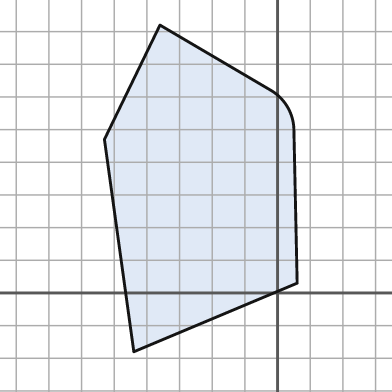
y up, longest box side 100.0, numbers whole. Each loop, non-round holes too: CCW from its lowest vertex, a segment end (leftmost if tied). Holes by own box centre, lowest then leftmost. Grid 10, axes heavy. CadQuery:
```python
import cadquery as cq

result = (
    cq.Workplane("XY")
    .moveTo(-44.0, -18.0)
    .lineTo(6.0, 3.0)
    .lineTo(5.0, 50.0)
    .threePointArc((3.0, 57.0), (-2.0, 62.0))
    .lineTo(-36.0, 82.0)
    .lineTo(-53.0, 47.0)
    .close()
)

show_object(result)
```